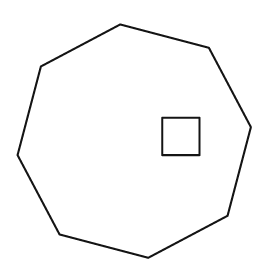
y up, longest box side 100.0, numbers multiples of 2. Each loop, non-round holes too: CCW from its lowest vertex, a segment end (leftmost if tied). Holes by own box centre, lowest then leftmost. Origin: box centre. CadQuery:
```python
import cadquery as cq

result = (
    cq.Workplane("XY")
    .moveTo(6.0, -50.0)
    .lineTo(40.0, -32.0)
    .lineTo(50.0, 6.0)
    .lineTo(32.0, 40.0)
    .lineTo(-6.0, 50.0)
    .lineTo(-40.0, 32.0)
    .lineTo(-50.0, -6.0)
    .lineTo(-32.0, -40.0)
    .close()
    .moveTo(12.0, -6.0)
    .lineTo(28.0, -6.0)
    .lineTo(28.0, 10.0)
    .lineTo(12.0, 10.0)
    .close()
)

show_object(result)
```